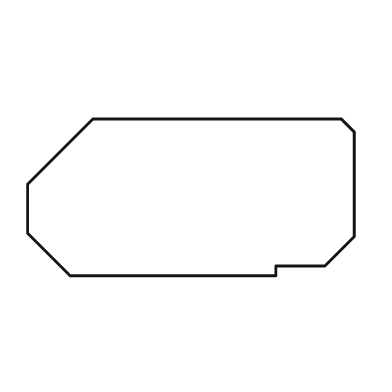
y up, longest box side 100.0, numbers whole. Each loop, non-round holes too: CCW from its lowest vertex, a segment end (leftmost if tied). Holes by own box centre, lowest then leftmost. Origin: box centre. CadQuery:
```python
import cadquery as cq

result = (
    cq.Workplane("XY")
    .moveTo(-37.0, -24.0)
    .lineTo(26.0, -24.0)
    .lineTo(26.0, -21.0)
    .lineTo(41.0, -21.0)
    .lineTo(50.0, -12.0)
    .lineTo(50.0, 20.0)
    .lineTo(46.0, 24.0)
    .lineTo(-30.0, 24.0)
    .lineTo(-50.0, 4.0)
    .lineTo(-50.0, -11.0)
    .close()
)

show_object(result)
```